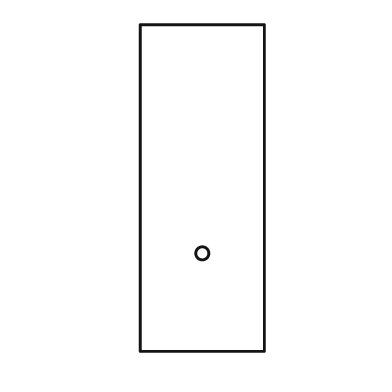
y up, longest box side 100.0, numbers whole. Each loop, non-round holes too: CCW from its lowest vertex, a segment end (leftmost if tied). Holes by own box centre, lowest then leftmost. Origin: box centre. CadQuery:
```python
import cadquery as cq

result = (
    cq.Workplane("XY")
    .moveTo(-19.0, -50.0)
    .lineTo(19.0, -50.0)
    .lineTo(19.0, 50.0)
    .lineTo(-19.0, 50.0)
    .close()
    .moveTo(0.0, -20.0)
    .circle(2.0)
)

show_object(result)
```